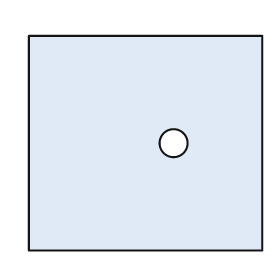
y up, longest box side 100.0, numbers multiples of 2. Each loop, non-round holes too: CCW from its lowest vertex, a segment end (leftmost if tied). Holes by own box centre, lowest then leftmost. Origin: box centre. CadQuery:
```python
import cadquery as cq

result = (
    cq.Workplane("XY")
    .moveTo(-50.0, -46.0)
    .lineTo(50.0, -46.0)
    .lineTo(50.0, 46.0)
    .lineTo(-50.0, 46.0)
    .close()
    .moveTo(12.0, 0.0)
    .circle(6.0)
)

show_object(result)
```